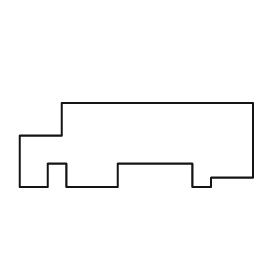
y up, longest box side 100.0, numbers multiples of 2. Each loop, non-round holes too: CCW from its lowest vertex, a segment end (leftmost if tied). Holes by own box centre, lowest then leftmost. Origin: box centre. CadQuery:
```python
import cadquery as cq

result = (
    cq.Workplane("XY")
    .moveTo(-50.0, -18.0)
    .lineTo(-38.0, -18.0)
    .lineTo(-38.0, -8.0)
    .lineTo(-30.0, -8.0)
    .lineTo(-30.0, -18.0)
    .lineTo(-8.0, -18.0)
    .lineTo(-8.0, -8.0)
    .lineTo(24.0, -8.0)
    .lineTo(24.0, -18.0)
    .lineTo(32.0, -18.0)
    .lineTo(32.0, -14.0)
    .lineTo(50.0, -14.0)
    .lineTo(50.0, 18.0)
    .lineTo(-32.0, 18.0)
    .lineTo(-32.0, 4.0)
    .lineTo(-50.0, 4.0)
    .close()
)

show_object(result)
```